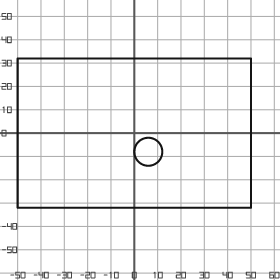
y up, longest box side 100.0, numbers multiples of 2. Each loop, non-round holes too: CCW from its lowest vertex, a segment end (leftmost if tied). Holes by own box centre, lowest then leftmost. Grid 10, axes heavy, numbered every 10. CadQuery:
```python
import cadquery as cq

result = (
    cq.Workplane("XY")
    .moveTo(-50.0, -32.0)
    .lineTo(50.0, -32.0)
    .lineTo(50.0, 32.0)
    .lineTo(-50.0, 32.0)
    .close()
    .moveTo(6.0, -8.0)
    .circle(6.0)
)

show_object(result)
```